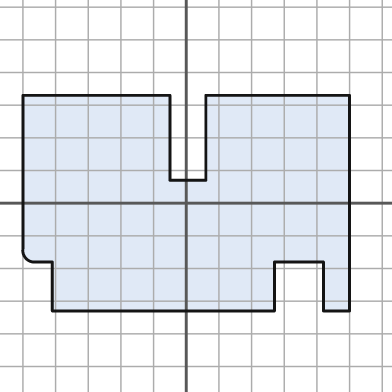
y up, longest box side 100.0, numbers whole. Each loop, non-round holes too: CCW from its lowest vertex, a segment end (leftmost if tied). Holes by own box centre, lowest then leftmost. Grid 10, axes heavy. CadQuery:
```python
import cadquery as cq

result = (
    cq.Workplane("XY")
    .moveTo(-41.0, -33.0)
    .lineTo(27.0, -33.0)
    .lineTo(27.0, -18.0)
    .lineTo(42.0, -18.0)
    .lineTo(42.0, -33.0)
    .lineTo(50.0, -33.0)
    .lineTo(50.0, 33.0)
    .lineTo(6.0, 33.0)
    .lineTo(6.0, 7.0)
    .lineTo(-5.0, 7.0)
    .lineTo(-5.0, 33.0)
    .lineTo(-50.0, 33.0)
    .lineTo(-50.0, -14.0)
    .threePointArc((-49.0, -17.0), (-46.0, -18.0))
    .lineTo(-41.0, -18.0)
    .close()
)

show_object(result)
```